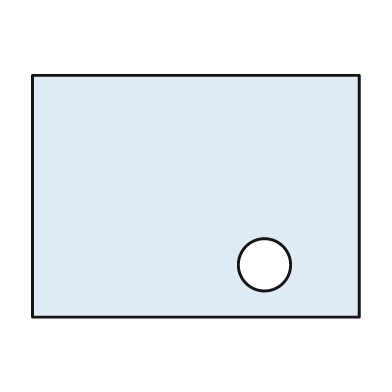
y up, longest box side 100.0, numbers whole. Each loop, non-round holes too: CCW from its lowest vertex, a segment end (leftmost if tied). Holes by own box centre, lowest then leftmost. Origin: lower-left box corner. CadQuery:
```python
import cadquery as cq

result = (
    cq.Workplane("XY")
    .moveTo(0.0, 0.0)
    .lineTo(100.0, 0.0)
    .lineTo(100.0, 74.0)
    .lineTo(0.0, 74.0)
    .close()
    .moveTo(71.0, 16.0)
    .circle(8.0)
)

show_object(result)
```